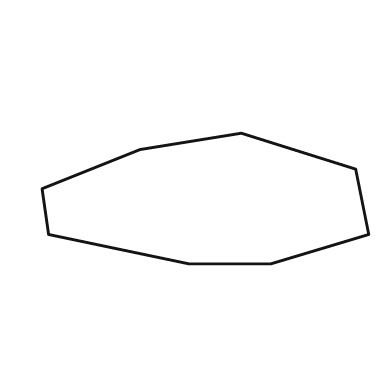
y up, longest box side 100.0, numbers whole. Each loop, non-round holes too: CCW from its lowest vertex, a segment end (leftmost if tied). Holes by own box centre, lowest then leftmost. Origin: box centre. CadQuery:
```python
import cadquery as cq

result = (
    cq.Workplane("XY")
    .moveTo(-5.0, -20.0)
    .lineTo(20.0, -20.0)
    .lineTo(50.0, -11.0)
    .lineTo(46.0, 9.0)
    .lineTo(11.0, 20.0)
    .lineTo(-20.0, 15.0)
    .lineTo(-50.0, 3.0)
    .lineTo(-48.0, -11.0)
    .close()
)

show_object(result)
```